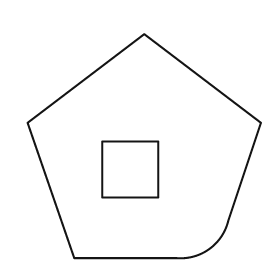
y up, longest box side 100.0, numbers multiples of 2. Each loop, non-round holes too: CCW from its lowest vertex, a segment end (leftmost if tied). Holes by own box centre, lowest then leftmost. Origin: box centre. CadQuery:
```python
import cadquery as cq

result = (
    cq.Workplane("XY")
    .moveTo(-30.0, -48.0)
    .lineTo(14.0, -48.0)
    .threePointArc((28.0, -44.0), (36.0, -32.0))
    .lineTo(50.0, 10.0)
    .lineTo(0.0, 48.0)
    .lineTo(-50.0, 10.0)
    .close()
    .moveTo(-18.0, -22.0)
    .lineTo(6.0, -22.0)
    .lineTo(6.0, 2.0)
    .lineTo(-18.0, 2.0)
    .close()
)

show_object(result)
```